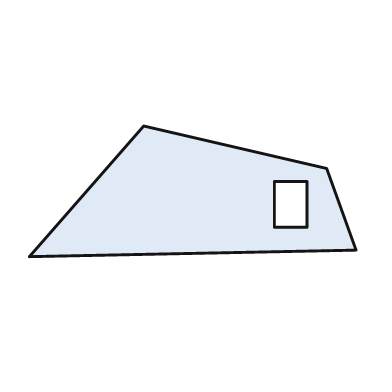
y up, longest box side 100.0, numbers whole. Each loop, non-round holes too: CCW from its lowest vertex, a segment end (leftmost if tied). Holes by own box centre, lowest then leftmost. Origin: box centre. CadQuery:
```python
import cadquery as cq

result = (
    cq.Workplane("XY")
    .moveTo(-50.0, -20.0)
    .lineTo(50.0, -18.0)
    .lineTo(41.0, 7.0)
    .lineTo(-15.0, 20.0)
    .close()
    .moveTo(25.0, -11.0)
    .lineTo(35.0, -11.0)
    .lineTo(35.0, 3.0)
    .lineTo(25.0, 3.0)
    .close()
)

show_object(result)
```